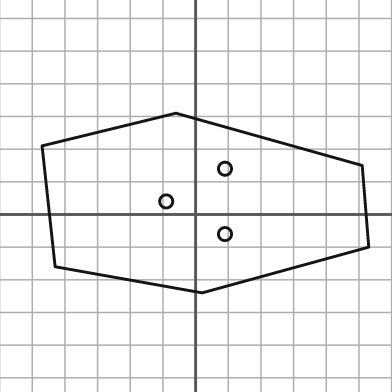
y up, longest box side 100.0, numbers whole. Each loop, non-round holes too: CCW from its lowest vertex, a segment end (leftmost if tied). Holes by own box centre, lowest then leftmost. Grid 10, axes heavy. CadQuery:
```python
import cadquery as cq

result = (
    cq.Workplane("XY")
    .moveTo(2.0, -24.0)
    .lineTo(53.0, -10.0)
    .lineTo(51.0, 15.0)
    .lineTo(-6.0, 31.0)
    .lineTo(-47.0, 21.0)
    .lineTo(-43.0, -16.0)
    .close()
    .moveTo(9.0, -6.0)
    .circle(2.0)
    .moveTo(-9.0, 4.0)
    .circle(2.0)
    .moveTo(9.0, 14.0)
    .circle(2.0)
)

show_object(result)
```